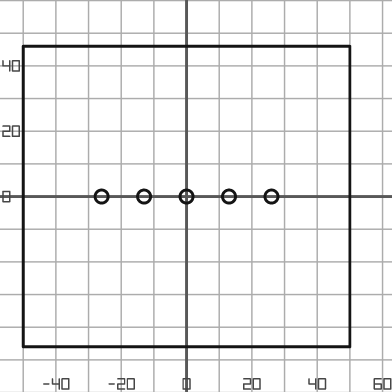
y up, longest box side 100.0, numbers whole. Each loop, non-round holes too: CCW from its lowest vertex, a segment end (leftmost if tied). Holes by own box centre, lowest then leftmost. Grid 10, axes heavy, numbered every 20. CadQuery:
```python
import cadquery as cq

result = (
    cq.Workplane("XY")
    .moveTo(-50.0, -46.0)
    .lineTo(50.0, -46.0)
    .lineTo(50.0, 46.0)
    .lineTo(-50.0, 46.0)
    .close()
    .moveTo(-26.0, 0.0)
    .circle(2.0)
    .moveTo(-13.0, 0.0)
    .circle(2.0)
    .moveTo(0.0, 0.0)
    .circle(2.0)
    .moveTo(13.0, 0.0)
    .circle(2.0)
    .moveTo(26.0, 0.0)
    .circle(2.0)
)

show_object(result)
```